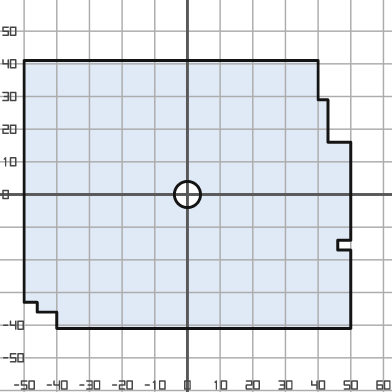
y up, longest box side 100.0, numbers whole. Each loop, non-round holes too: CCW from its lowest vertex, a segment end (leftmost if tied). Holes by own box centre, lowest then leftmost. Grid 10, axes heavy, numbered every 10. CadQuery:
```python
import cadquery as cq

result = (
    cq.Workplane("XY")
    .moveTo(-40.0, -41.0)
    .lineTo(50.0, -41.0)
    .lineTo(50.0, -17.0)
    .lineTo(46.0, -17.0)
    .lineTo(46.0, -14.0)
    .lineTo(50.0, -14.0)
    .lineTo(50.0, 16.0)
    .lineTo(43.0, 16.0)
    .lineTo(43.0, 29.0)
    .lineTo(40.0, 29.0)
    .lineTo(40.0, 41.0)
    .lineTo(-50.0, 41.0)
    .lineTo(-50.0, -33.0)
    .lineTo(-46.0, -33.0)
    .lineTo(-46.0, -36.0)
    .lineTo(-40.0, -36.0)
    .close()
    .moveTo(0.0, 0.0)
    .circle(4.0)
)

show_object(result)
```